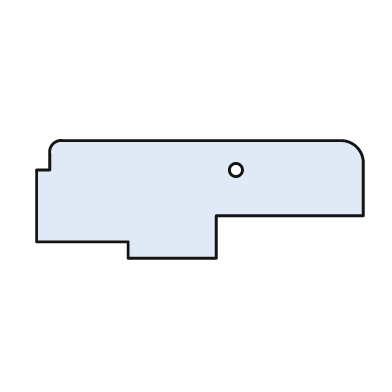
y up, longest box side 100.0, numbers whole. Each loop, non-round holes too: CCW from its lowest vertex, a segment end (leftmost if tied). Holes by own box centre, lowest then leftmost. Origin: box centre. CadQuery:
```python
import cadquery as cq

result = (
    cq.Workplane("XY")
    .moveTo(-22.0, -18.0)
    .lineTo(5.0, -18.0)
    .lineTo(5.0, -5.0)
    .lineTo(50.0, -5.0)
    .lineTo(50.0, 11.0)
    .threePointArc((48.0, 16.0), (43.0, 18.0))
    .lineTo(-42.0, 18.0)
    .threePointArc((-45.0, 17.0), (-46.0, 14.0))
    .lineTo(-46.0, 9.0)
    .lineTo(-50.0, 9.0)
    .lineTo(-50.0, -13.0)
    .lineTo(-22.0, -13.0)
    .close()
    .moveTo(11.0, 9.0)
    .circle(2.0)
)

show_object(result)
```